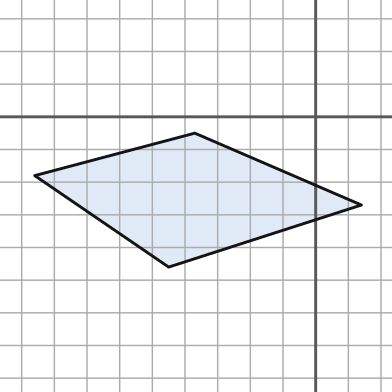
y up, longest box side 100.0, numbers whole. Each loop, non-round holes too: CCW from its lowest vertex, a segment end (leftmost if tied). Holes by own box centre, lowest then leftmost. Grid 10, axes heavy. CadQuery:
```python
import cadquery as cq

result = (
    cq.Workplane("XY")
    .moveTo(-45.0, -46.0)
    .lineTo(14.0, -27.0)
    .lineTo(-37.0, -5.0)
    .lineTo(-86.0, -18.0)
    .close()
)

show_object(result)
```